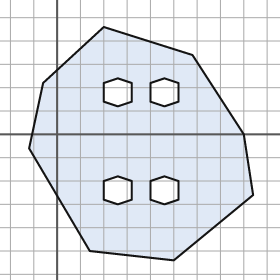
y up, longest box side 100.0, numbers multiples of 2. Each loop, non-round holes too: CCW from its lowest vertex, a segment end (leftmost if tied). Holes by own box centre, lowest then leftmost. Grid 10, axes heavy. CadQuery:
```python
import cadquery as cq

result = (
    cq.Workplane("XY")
    .moveTo(50.0, -54.0)
    .lineTo(84.0, -26.0)
    .lineTo(80.0, 0.0)
    .lineTo(58.0, 34.0)
    .lineTo(20.0, 46.0)
    .lineTo(-6.0, 22.0)
    .lineTo(-12.0, -6.0)
    .lineTo(14.0, -50.0)
    .close()
    .moveTo(26.0, -30.0)
    .lineTo(32.0, -28.0)
    .lineTo(32.0, -20.0)
    .lineTo(26.0, -18.0)
    .lineTo(20.0, -20.0)
    .lineTo(20.0, -28.0)
    .close()
    .moveTo(46.0, -30.0)
    .lineTo(52.0, -28.0)
    .lineTo(52.0, -20.0)
    .lineTo(46.0, -18.0)
    .lineTo(40.0, -20.0)
    .lineTo(40.0, -28.0)
    .close()
    .moveTo(26.0, 12.0)
    .lineTo(32.0, 14.0)
    .lineTo(32.0, 22.0)
    .lineTo(26.0, 24.0)
    .lineTo(20.0, 22.0)
    .lineTo(20.0, 14.0)
    .close()
    .moveTo(46.0, 12.0)
    .lineTo(52.0, 14.0)
    .lineTo(52.0, 22.0)
    .lineTo(46.0, 24.0)
    .lineTo(40.0, 22.0)
    .lineTo(40.0, 14.0)
    .close()
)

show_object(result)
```